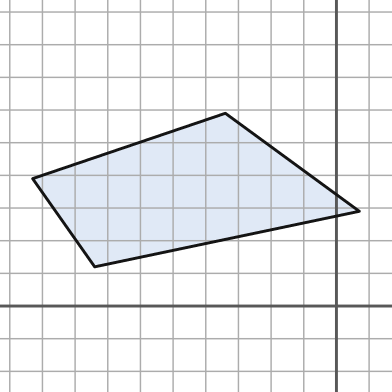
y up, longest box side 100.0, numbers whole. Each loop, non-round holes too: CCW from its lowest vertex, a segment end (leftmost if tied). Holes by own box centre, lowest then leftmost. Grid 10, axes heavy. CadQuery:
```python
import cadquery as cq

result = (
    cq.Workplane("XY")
    .moveTo(-74.0, 12.0)
    .lineTo(7.0, 29.0)
    .lineTo(-34.0, 59.0)
    .lineTo(-93.0, 39.0)
    .close()
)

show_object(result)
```